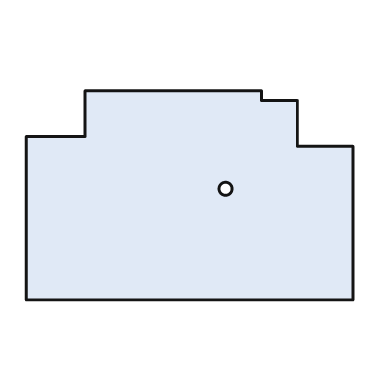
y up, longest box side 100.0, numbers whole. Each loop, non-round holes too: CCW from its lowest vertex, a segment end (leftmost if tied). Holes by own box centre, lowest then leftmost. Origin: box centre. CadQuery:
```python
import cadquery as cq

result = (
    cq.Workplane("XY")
    .moveTo(-50.0, -32.0)
    .lineTo(50.0, -32.0)
    .lineTo(50.0, 15.0)
    .lineTo(33.0, 15.0)
    .lineTo(33.0, 29.0)
    .lineTo(22.0, 29.0)
    .lineTo(22.0, 32.0)
    .lineTo(-32.0, 32.0)
    .lineTo(-32.0, 18.0)
    .lineTo(-50.0, 18.0)
    .close()
    .moveTo(11.0, 2.0)
    .circle(2.0)
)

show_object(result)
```